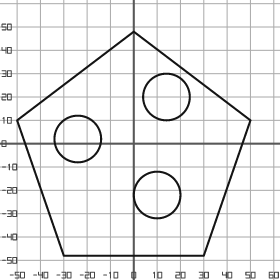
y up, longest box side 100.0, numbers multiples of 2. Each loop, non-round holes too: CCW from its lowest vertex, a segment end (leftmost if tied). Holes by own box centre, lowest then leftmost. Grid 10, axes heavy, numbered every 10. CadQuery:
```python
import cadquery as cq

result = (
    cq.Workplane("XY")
    .moveTo(-30.0, -48.0)
    .lineTo(30.0, -48.0)
    .lineTo(50.0, 10.0)
    .lineTo(0.0, 48.0)
    .lineTo(-50.0, 10.0)
    .close()
    .moveTo(10.0, -22.0)
    .circle(10.0)
    .moveTo(-24.0, 2.0)
    .circle(10.0)
    .moveTo(14.0, 20.0)
    .circle(10.0)
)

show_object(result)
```